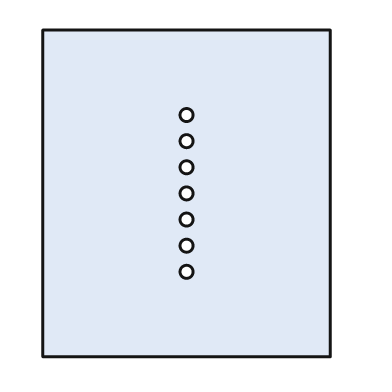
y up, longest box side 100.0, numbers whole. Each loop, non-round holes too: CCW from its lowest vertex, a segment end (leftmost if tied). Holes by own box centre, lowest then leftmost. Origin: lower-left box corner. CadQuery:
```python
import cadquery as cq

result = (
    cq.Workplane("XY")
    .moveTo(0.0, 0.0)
    .lineTo(88.0, 0.0)
    .lineTo(88.0, 100.0)
    .lineTo(0.0, 100.0)
    .close()
    .moveTo(44.0, 26.0)
    .circle(2.0)
    .moveTo(44.0, 34.0)
    .circle(2.0)
    .moveTo(44.0, 42.0)
    .circle(2.0)
    .moveTo(44.0, 50.0)
    .circle(2.0)
    .moveTo(44.0, 58.0)
    .circle(2.0)
    .moveTo(44.0, 66.0)
    .circle(2.0)
    .moveTo(44.0, 74.0)
    .circle(2.0)
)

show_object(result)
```